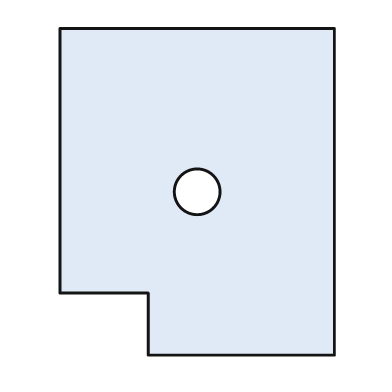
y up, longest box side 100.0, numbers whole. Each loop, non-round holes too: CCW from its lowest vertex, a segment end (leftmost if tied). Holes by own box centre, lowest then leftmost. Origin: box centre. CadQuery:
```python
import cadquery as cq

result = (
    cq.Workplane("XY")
    .moveTo(-15.0, -50.0)
    .lineTo(42.0, -50.0)
    .lineTo(42.0, 50.0)
    .lineTo(-42.0, 50.0)
    .lineTo(-42.0, -31.0)
    .lineTo(-15.0, -31.0)
    .close()
    .moveTo(0.0, 0.0)
    .circle(7.0)
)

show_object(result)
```